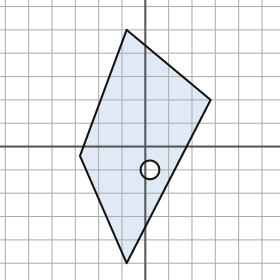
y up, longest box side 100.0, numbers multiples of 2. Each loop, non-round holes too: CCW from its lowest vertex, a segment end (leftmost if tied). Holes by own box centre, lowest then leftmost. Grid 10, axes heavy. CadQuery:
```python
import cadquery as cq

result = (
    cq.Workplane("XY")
    .moveTo(-8.0, -50.0)
    .lineTo(28.0, 20.0)
    .lineTo(-8.0, 50.0)
    .lineTo(-28.0, -4.0)
    .close()
    .moveTo(2.0, -10.0)
    .circle(4.0)
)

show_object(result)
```